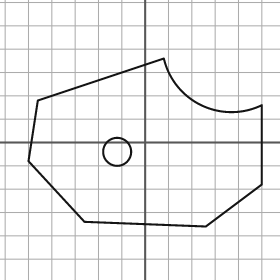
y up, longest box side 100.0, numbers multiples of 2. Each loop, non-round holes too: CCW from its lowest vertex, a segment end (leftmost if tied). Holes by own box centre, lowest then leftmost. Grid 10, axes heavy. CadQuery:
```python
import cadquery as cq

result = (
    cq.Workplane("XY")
    .moveTo(26.0, -36.0)
    .lineTo(50.0, -18.0)
    .lineTo(50.0, 16.0)
    .threePointArc((24.0, 16.0), (8.0, 36.0))
    .lineTo(-46.0, 18.0)
    .lineTo(-50.0, -8.0)
    .lineTo(-26.0, -34.0)
    .close()
    .moveTo(-12.0, -4.0)
    .circle(6.0)
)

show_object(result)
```